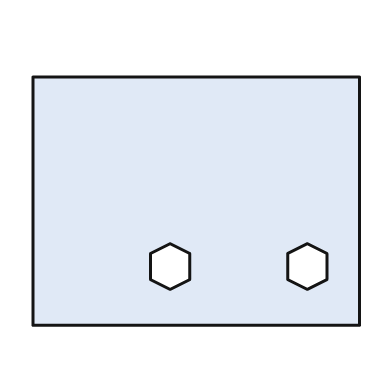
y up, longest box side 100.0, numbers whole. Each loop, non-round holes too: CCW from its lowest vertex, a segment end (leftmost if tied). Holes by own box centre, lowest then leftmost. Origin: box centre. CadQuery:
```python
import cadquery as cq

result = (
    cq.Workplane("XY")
    .moveTo(-50.0, -38.0)
    .lineTo(50.0, -38.0)
    .lineTo(50.0, 38.0)
    .lineTo(-50.0, 38.0)
    .close()
    .moveTo(-8.0, -27.0)
    .lineTo(-2.0, -24.0)
    .lineTo(-2.0, -16.0)
    .lineTo(-8.0, -13.0)
    .lineTo(-14.0, -16.0)
    .lineTo(-14.0, -24.0)
    .close()
    .moveTo(34.0, -27.0)
    .lineTo(40.0, -24.0)
    .lineTo(40.0, -16.0)
    .lineTo(34.0, -13.0)
    .lineTo(28.0, -16.0)
    .lineTo(28.0, -24.0)
    .close()
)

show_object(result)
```